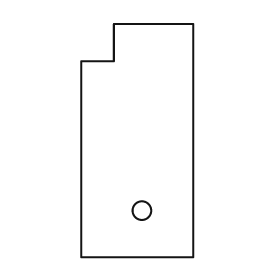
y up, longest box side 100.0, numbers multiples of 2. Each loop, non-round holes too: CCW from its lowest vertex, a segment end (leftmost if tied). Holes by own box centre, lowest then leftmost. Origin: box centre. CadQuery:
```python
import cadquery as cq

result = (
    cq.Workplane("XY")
    .moveTo(-24.0, -50.0)
    .lineTo(24.0, -50.0)
    .lineTo(24.0, 50.0)
    .lineTo(-10.0, 50.0)
    .lineTo(-10.0, 34.0)
    .lineTo(-24.0, 34.0)
    .close()
    .moveTo(2.0, -30.0)
    .circle(4.0)
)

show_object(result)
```